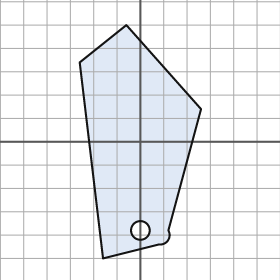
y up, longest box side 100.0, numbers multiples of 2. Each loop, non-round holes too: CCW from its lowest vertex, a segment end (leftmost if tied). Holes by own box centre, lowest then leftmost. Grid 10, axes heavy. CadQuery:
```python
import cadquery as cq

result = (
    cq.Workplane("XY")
    .moveTo(-16.0, -50.0)
    .lineTo(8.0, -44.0)
    .threePointArc((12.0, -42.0), (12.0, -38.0))
    .lineTo(26.0, 14.0)
    .lineTo(-6.0, 50.0)
    .lineTo(-26.0, 34.0)
    .close()
    .moveTo(0.0, -38.0)
    .circle(4.0)
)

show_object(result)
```